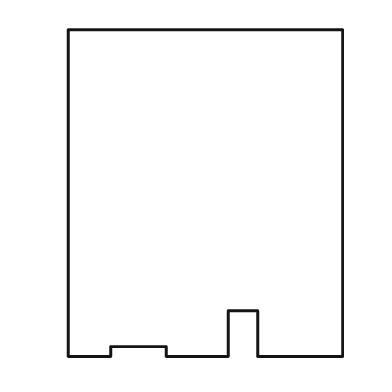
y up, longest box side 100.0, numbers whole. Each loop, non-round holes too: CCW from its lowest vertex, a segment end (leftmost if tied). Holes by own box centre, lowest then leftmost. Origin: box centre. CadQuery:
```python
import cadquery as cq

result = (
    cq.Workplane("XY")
    .moveTo(-42.0, -50.0)
    .lineTo(-29.0, -50.0)
    .lineTo(-29.0, -47.0)
    .lineTo(-12.0, -47.0)
    .lineTo(-12.0, -50.0)
    .lineTo(7.0, -50.0)
    .lineTo(7.0, -36.0)
    .lineTo(16.0, -36.0)
    .lineTo(16.0, -50.0)
    .lineTo(42.0, -50.0)
    .lineTo(42.0, 50.0)
    .lineTo(-42.0, 50.0)
    .close()
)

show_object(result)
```